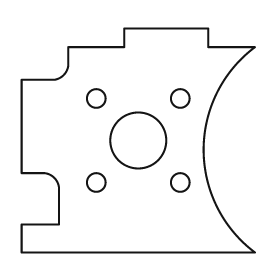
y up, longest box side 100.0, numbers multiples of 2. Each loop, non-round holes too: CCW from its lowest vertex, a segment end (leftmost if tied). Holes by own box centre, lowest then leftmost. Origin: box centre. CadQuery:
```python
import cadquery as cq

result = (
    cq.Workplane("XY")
    .moveTo(-50.0, -48.0)
    .lineTo(50.0, -48.0)
    .threePointArc((28.0, -4.0), (50.0, 40.0))
    .lineTo(30.0, 40.0)
    .lineTo(30.0, 48.0)
    .lineTo(-6.0, 48.0)
    .lineTo(-6.0, 40.0)
    .lineTo(-30.0, 40.0)
    .lineTo(-30.0, 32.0)
    .threePointArc((-32.0, 28.0), (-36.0, 26.0))
    .lineTo(-50.0, 26.0)
    .lineTo(-50.0, -14.0)
    .lineTo(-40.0, -14.0)
    .threePointArc((-36.0, -16.0), (-34.0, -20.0))
    .lineTo(-34.0, -36.0)
    .lineTo(-50.0, -36.0)
    .close()
    .moveTo(-18.0, -18.0)
    .circle(4.0)
    .moveTo(18.0, -18.0)
    .circle(4.0)
    .moveTo(0.0, 0.0)
    .circle(12.0)
    .moveTo(-18.0, 18.0)
    .circle(4.0)
    .moveTo(18.0, 18.0)
    .circle(4.0)
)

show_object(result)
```